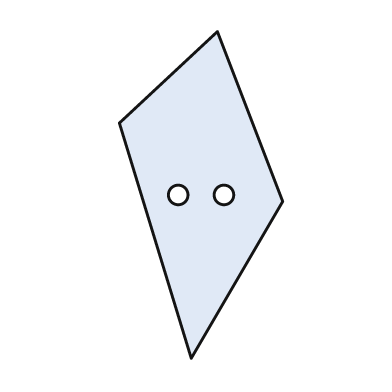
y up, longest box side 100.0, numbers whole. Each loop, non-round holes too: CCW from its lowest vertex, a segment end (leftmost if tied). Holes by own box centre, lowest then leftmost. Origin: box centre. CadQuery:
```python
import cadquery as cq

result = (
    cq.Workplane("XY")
    .moveTo(-3.0, -50.0)
    .lineTo(25.0, -2.0)
    .lineTo(5.0, 50.0)
    .lineTo(-25.0, 22.0)
    .close()
    .moveTo(-7.0, 0.0)
    .circle(3.0)
    .moveTo(7.0, 0.0)
    .circle(3.0)
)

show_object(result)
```